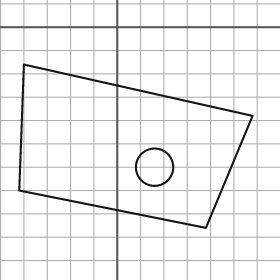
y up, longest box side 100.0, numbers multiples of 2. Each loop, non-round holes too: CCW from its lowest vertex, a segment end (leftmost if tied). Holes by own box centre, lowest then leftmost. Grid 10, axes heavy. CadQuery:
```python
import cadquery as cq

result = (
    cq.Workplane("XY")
    .moveTo(38.0, -86.0)
    .lineTo(58.0, -38.0)
    .lineTo(-40.0, -16.0)
    .lineTo(-42.0, -70.0)
    .close()
    .moveTo(16.0, -60.0)
    .circle(8.0)
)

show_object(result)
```